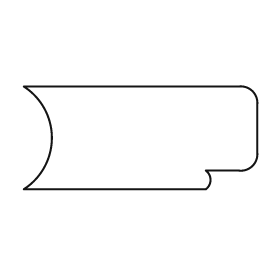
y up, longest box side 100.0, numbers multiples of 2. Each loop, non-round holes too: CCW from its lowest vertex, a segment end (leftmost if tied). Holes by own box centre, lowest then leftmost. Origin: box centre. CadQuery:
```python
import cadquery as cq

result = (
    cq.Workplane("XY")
    .moveTo(-50.0, -22.0)
    .lineTo(28.0, -22.0)
    .threePointArc((30.0, -18.0), (28.0, -14.0))
    .lineTo(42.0, -14.0)
    .threePointArc((48.0, -12.0), (50.0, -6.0))
    .lineTo(50.0, 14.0)
    .threePointArc((48.0, 20.0), (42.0, 22.0))
    .lineTo(-50.0, 22.0)
    .threePointArc((-38.0, 0.0), (-50.0, -22.0))
    .close()
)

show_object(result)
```